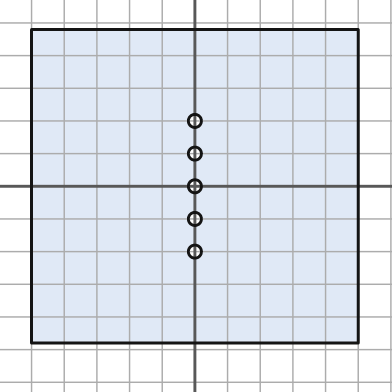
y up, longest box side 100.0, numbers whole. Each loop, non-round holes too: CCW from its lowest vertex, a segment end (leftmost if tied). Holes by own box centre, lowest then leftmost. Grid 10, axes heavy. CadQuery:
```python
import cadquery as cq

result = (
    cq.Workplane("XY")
    .moveTo(-50.0, -48.0)
    .lineTo(50.0, -48.0)
    .lineTo(50.0, 48.0)
    .lineTo(-50.0, 48.0)
    .close()
    .moveTo(0.0, -20.0)
    .circle(2.0)
    .moveTo(0.0, -10.0)
    .circle(2.0)
    .moveTo(0.0, 0.0)
    .circle(2.0)
    .moveTo(0.0, 10.0)
    .circle(2.0)
    .moveTo(0.0, 20.0)
    .circle(2.0)
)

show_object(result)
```